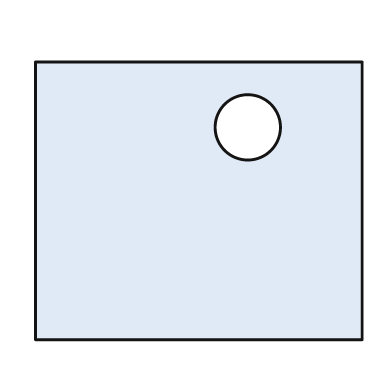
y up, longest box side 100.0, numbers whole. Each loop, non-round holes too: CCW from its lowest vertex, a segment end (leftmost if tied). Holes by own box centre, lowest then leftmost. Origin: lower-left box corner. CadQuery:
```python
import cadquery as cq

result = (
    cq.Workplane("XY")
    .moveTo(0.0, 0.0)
    .lineTo(100.0, 0.0)
    .lineTo(100.0, 85.0)
    .lineTo(0.0, 85.0)
    .close()
    .moveTo(65.0, 65.0)
    .circle(10.0)
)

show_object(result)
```